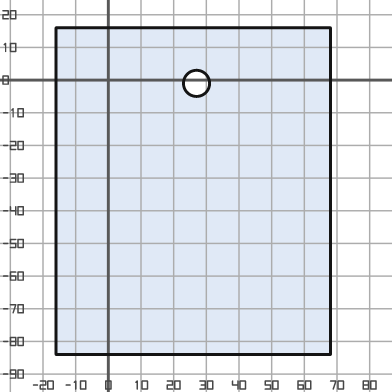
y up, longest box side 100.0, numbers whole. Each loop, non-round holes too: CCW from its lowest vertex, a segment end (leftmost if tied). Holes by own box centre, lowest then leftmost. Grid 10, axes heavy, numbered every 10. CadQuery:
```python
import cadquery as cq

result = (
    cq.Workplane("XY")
    .moveTo(-16.0, -84.0)
    .lineTo(68.0, -84.0)
    .lineTo(68.0, 16.0)
    .lineTo(-16.0, 16.0)
    .close()
    .moveTo(27.0, -1.0)
    .circle(4.0)
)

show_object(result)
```